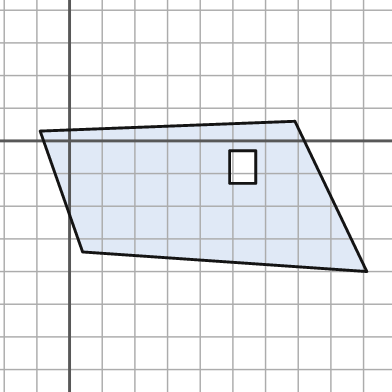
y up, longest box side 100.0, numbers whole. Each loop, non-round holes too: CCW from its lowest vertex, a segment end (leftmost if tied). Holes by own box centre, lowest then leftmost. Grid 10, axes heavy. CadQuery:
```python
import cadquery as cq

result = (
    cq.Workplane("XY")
    .moveTo(91.0, -40.0)
    .lineTo(69.0, 6.0)
    .lineTo(-9.0, 3.0)
    .lineTo(4.0, -34.0)
    .close()
    .moveTo(49.0, -13.0)
    .lineTo(57.0, -13.0)
    .lineTo(57.0, -3.0)
    .lineTo(49.0, -3.0)
    .close()
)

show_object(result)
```